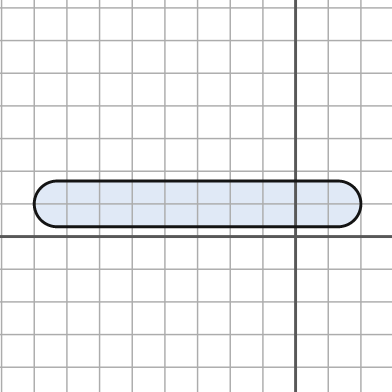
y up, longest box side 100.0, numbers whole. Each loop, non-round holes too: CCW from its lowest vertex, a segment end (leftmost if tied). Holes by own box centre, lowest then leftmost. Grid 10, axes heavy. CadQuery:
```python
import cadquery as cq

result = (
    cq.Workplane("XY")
    .moveTo(-73.0, 3.0)
    .lineTo(13.0, 3.0)
    .threePointArc((20.0, 10.0), (13.0, 17.0))
    .lineTo(-73.0, 17.0)
    .threePointArc((-80.0, 10.0), (-73.0, 3.0))
    .close()
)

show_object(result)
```